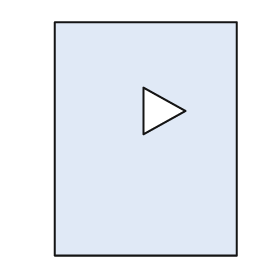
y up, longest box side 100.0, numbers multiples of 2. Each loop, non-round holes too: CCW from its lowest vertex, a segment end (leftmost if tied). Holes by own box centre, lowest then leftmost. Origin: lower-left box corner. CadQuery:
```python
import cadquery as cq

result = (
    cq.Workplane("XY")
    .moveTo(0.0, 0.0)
    .lineTo(78.0, 0.0)
    .lineTo(78.0, 100.0)
    .lineTo(0.0, 100.0)
    .close()
    .moveTo(38.0, 52.0)
    .lineTo(56.0, 62.0)
    .lineTo(38.0, 72.0)
    .close()
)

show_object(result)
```